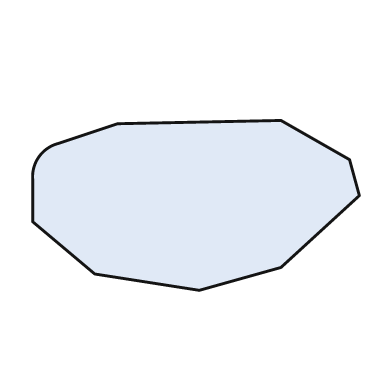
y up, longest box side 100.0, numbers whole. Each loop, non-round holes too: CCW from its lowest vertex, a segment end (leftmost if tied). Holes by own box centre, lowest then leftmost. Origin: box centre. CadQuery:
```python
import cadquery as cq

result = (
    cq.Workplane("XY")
    .moveTo(1.0, -26.0)
    .lineTo(26.0, -19.0)
    .lineTo(50.0, 3.0)
    .lineTo(47.0, 14.0)
    .lineTo(26.0, 26.0)
    .lineTo(-24.0, 25.0)
    .lineTo(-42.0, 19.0)
    .threePointArc((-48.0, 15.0), (-50.0, 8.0))
    .lineTo(-50.0, -5.0)
    .lineTo(-31.0, -21.0)
    .close()
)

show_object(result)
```